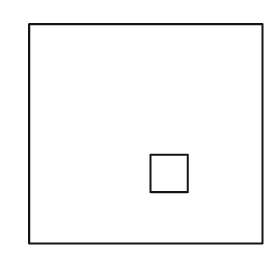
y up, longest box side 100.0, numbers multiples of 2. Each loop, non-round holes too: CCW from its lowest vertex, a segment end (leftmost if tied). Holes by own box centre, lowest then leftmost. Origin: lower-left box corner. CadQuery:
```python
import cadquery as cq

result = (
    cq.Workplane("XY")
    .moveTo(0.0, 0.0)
    .lineTo(100.0, 0.0)
    .lineTo(100.0, 94.0)
    .lineTo(0.0, 94.0)
    .close()
    .moveTo(52.0, 22.0)
    .lineTo(68.0, 22.0)
    .lineTo(68.0, 38.0)
    .lineTo(52.0, 38.0)
    .close()
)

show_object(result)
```